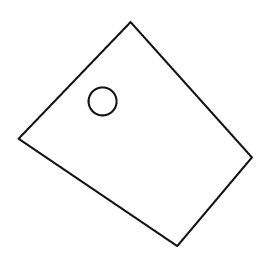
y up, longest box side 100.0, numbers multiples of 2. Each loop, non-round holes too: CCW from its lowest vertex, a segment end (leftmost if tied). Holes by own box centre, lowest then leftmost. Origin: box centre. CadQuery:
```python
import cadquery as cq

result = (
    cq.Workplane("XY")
    .moveTo(18.0, -48.0)
    .lineTo(50.0, -10.0)
    .lineTo(-2.0, 48.0)
    .lineTo(-50.0, -2.0)
    .close()
    .moveTo(-14.0, 14.0)
    .circle(6.0)
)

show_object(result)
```